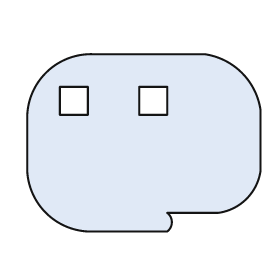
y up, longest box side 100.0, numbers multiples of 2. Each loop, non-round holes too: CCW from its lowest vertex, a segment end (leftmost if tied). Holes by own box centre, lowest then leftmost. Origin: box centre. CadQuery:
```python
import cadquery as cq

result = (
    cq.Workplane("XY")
    .moveTo(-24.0, -38.0)
    .lineTo(10.0, -38.0)
    .threePointArc((12.0, -34.0), (10.0, -30.0))
    .lineTo(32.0, -30.0)
    .threePointArc((44.0, -24.0), (50.0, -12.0))
    .lineTo(50.0, 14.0)
    .threePointArc((42.0, 30.0), (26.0, 38.0))
    .lineTo(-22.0, 38.0)
    .threePointArc((-42.0, 30.0), (-50.0, 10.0))
    .lineTo(-50.0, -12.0)
    .threePointArc((-42.0, -30.0), (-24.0, -38.0))
    .close()
    .moveTo(-36.0, 12.0)
    .lineTo(-24.0, 12.0)
    .lineTo(-24.0, 24.0)
    .lineTo(-36.0, 24.0)
    .close()
    .moveTo(-2.0, 12.0)
    .lineTo(10.0, 12.0)
    .lineTo(10.0, 24.0)
    .lineTo(-2.0, 24.0)
    .close()
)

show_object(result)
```